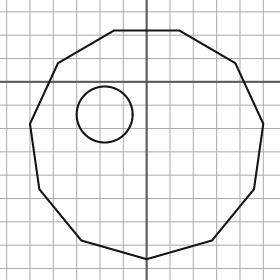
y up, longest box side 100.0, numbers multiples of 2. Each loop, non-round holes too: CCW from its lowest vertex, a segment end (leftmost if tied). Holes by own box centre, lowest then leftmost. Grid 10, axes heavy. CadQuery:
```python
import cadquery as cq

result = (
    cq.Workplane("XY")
    .moveTo(0.0, -76.0)
    .lineTo(28.0, -68.0)
    .lineTo(46.0, -46.0)
    .lineTo(50.0, -18.0)
    .lineTo(38.0, 8.0)
    .lineTo(14.0, 22.0)
    .lineTo(-14.0, 22.0)
    .lineTo(-38.0, 8.0)
    .lineTo(-50.0, -18.0)
    .lineTo(-46.0, -46.0)
    .lineTo(-28.0, -68.0)
    .close()
    .moveTo(-18.0, -14.0)
    .circle(12.0)
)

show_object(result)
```